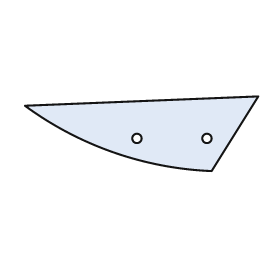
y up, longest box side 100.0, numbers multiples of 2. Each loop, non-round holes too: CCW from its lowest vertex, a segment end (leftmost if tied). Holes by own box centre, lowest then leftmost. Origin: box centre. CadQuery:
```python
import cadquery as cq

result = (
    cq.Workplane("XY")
    .moveTo(30.0, -16.0)
    .lineTo(50.0, 16.0)
    .lineTo(-50.0, 12.0)
    .threePointArc((-12.0, -8.0), (30.0, -16.0))
    .close()
    .moveTo(-2.0, -2.0)
    .circle(2.0)
    .moveTo(28.0, -2.0)
    .circle(2.0)
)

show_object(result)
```